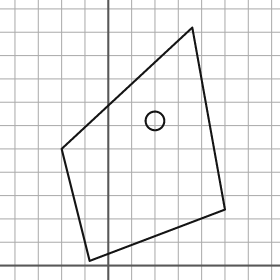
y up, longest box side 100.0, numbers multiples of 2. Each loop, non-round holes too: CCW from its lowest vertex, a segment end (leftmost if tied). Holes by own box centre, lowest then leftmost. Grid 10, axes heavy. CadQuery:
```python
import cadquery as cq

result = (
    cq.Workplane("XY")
    .moveTo(-8.0, 2.0)
    .lineTo(50.0, 24.0)
    .lineTo(36.0, 102.0)
    .lineTo(-20.0, 50.0)
    .close()
    .moveTo(20.0, 62.0)
    .circle(4.0)
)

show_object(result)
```